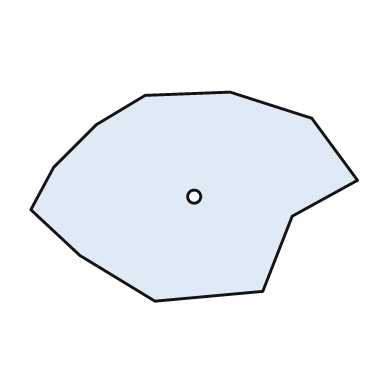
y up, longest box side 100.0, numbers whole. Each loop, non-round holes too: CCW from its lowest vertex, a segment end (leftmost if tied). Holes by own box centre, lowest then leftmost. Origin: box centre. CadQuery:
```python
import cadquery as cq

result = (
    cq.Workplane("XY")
    .moveTo(-12.0, -32.0)
    .lineTo(21.0, -29.0)
    .lineTo(30.0, -6.0)
    .lineTo(50.0, 5.0)
    .lineTo(36.0, 24.0)
    .lineTo(11.0, 32.0)
    .lineTo(-15.0, 31.0)
    .lineTo(-30.0, 22.0)
    .lineTo(-43.0, 9.0)
    .lineTo(-50.0, -4.0)
    .lineTo(-35.0, -18.0)
    .close()
    .moveTo(0.0, 0.0)
    .circle(2.0)
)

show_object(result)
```